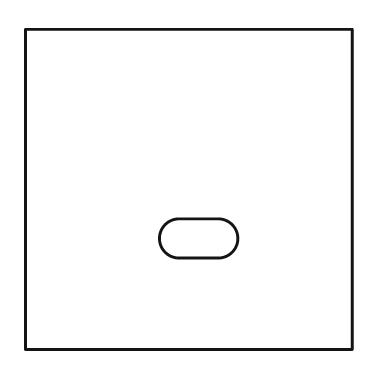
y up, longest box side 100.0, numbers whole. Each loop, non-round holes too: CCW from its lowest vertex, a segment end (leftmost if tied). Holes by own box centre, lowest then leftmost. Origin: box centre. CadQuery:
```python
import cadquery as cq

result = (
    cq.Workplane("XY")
    .moveTo(-50.0, -49.0)
    .lineTo(50.0, -49.0)
    .lineTo(50.0, 49.0)
    .lineTo(-50.0, 49.0)
    .close()
    .moveTo(-3.0, -21.0)
    .lineTo(9.0, -21.0)
    .threePointArc((15.0, -15.0), (9.0, -9.0))
    .lineTo(-3.0, -9.0)
    .threePointArc((-9.0, -15.0), (-3.0, -21.0))
    .close()
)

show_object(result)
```